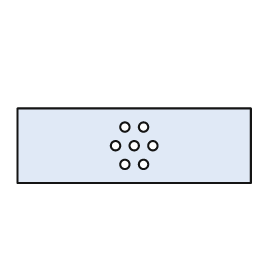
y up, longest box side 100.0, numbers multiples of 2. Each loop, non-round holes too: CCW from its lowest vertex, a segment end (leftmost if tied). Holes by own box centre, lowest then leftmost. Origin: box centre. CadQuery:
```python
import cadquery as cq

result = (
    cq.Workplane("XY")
    .moveTo(-50.0, -16.0)
    .lineTo(50.0, -16.0)
    .lineTo(50.0, 16.0)
    .lineTo(-50.0, 16.0)
    .close()
    .moveTo(-4.0, -8.0)
    .circle(2.0)
    .moveTo(4.0, -8.0)
    .circle(2.0)
    .moveTo(-8.0, 0.0)
    .circle(2.0)
    .moveTo(0.0, 0.0)
    .circle(2.0)
    .moveTo(8.0, 0.0)
    .circle(2.0)
    .moveTo(-4.0, 8.0)
    .circle(2.0)
    .moveTo(4.0, 8.0)
    .circle(2.0)
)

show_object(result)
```